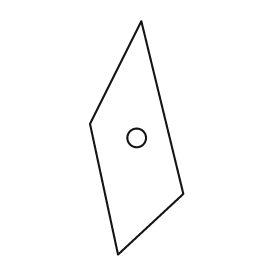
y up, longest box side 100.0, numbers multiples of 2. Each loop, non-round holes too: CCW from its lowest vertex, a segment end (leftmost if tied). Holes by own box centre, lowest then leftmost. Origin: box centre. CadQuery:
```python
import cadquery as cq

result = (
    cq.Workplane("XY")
    .moveTo(-8.0, -50.0)
    .lineTo(20.0, -24.0)
    .lineTo(2.0, 50.0)
    .lineTo(-20.0, 6.0)
    .close()
    .moveTo(0.0, 0.0)
    .circle(4.0)
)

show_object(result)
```